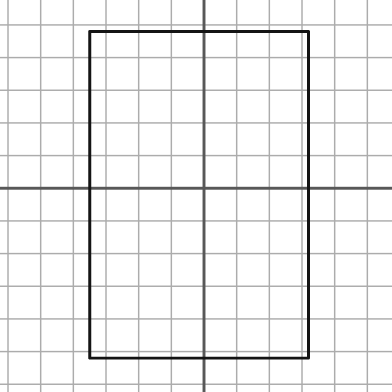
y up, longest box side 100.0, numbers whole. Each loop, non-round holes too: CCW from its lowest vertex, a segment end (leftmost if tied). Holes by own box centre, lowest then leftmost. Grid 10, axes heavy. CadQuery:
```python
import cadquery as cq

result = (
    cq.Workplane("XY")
    .moveTo(-35.0, -52.0)
    .lineTo(32.0, -52.0)
    .lineTo(32.0, 48.0)
    .lineTo(-35.0, 48.0)
    .close()
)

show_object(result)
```